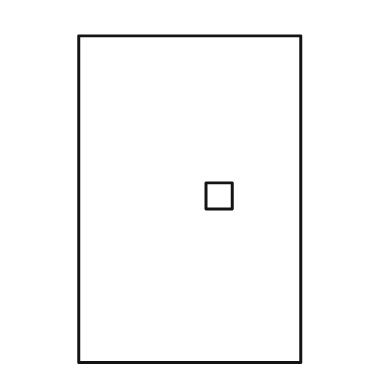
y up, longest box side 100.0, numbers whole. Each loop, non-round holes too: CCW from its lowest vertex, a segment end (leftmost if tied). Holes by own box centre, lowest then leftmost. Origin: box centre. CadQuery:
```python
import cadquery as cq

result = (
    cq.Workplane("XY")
    .moveTo(-34.0, -50.0)
    .lineTo(34.0, -50.0)
    .lineTo(34.0, 50.0)
    .lineTo(-34.0, 50.0)
    .close()
    .moveTo(5.0, -3.0)
    .lineTo(13.0, -3.0)
    .lineTo(13.0, 5.0)
    .lineTo(5.0, 5.0)
    .close()
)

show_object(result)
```